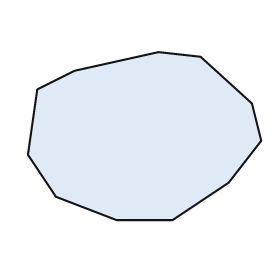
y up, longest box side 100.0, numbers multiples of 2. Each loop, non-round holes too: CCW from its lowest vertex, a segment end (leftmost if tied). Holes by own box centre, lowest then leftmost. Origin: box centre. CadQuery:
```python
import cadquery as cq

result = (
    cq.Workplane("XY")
    .moveTo(-12.0, -36.0)
    .lineTo(12.0, -36.0)
    .lineTo(36.0, -20.0)
    .lineTo(50.0, -2.0)
    .lineTo(46.0, 14.0)
    .lineTo(24.0, 34.0)
    .lineTo(6.0, 36.0)
    .lineTo(-30.0, 28.0)
    .lineTo(-46.0, 20.0)
    .lineTo(-50.0, -8.0)
    .lineTo(-38.0, -26.0)
    .close()
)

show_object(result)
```